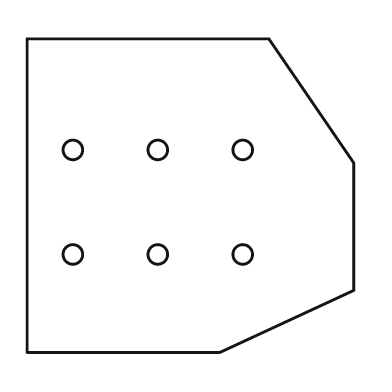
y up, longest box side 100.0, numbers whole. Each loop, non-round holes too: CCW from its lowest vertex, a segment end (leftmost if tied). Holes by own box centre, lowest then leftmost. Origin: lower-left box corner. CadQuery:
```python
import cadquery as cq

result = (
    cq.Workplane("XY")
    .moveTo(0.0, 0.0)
    .lineTo(59.0, 0.0)
    .lineTo(100.0, 19.0)
    .lineTo(100.0, 58.0)
    .lineTo(74.0, 96.0)
    .lineTo(0.0, 96.0)
    .close()
    .moveTo(14.0, 30.0)
    .circle(3.0)
    .moveTo(40.0, 30.0)
    .circle(3.0)
    .moveTo(66.0, 30.0)
    .circle(3.0)
    .moveTo(14.0, 62.0)
    .circle(3.0)
    .moveTo(40.0, 62.0)
    .circle(3.0)
    .moveTo(66.0, 62.0)
    .circle(3.0)
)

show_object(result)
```